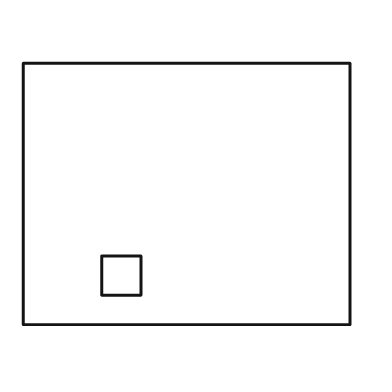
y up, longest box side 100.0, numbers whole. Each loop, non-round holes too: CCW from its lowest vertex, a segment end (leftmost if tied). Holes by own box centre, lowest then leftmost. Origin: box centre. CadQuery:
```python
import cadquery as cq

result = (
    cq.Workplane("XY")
    .moveTo(-50.0, -40.0)
    .lineTo(50.0, -40.0)
    .lineTo(50.0, 40.0)
    .lineTo(-50.0, 40.0)
    .close()
    .moveTo(-26.0, -31.0)
    .lineTo(-14.0, -31.0)
    .lineTo(-14.0, -19.0)
    .lineTo(-26.0, -19.0)
    .close()
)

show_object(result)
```